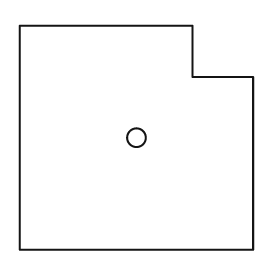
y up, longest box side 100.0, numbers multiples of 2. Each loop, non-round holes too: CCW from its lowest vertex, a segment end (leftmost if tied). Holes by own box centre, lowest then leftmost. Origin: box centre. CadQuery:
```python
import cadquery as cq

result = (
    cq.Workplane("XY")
    .moveTo(-50.0, -48.0)
    .lineTo(50.0, -48.0)
    .lineTo(50.0, 26.0)
    .lineTo(24.0, 26.0)
    .lineTo(24.0, 48.0)
    .lineTo(-50.0, 48.0)
    .close()
    .moveTo(0.0, 0.0)
    .circle(4.0)
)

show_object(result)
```